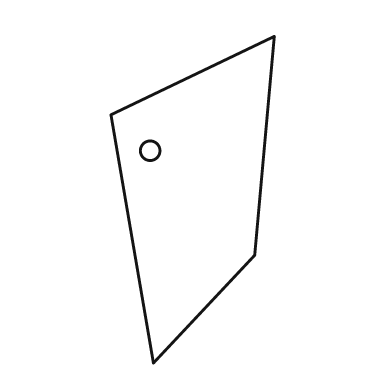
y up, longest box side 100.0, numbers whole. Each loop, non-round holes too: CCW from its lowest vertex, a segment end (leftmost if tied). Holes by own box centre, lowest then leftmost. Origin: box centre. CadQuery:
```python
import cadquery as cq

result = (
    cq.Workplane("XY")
    .moveTo(-12.0, -50.0)
    .lineTo(19.0, -17.0)
    .lineTo(25.0, 50.0)
    .lineTo(-25.0, 26.0)
    .close()
    .moveTo(-13.0, 15.0)
    .circle(3.0)
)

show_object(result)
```